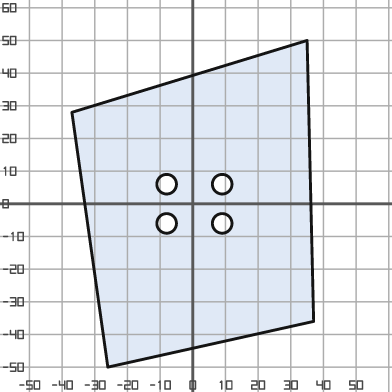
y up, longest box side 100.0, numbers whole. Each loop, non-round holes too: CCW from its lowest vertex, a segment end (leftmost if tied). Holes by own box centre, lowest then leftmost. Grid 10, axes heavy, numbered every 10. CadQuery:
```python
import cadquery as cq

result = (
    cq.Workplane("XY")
    .moveTo(-26.0, -50.0)
    .lineTo(37.0, -36.0)
    .lineTo(35.0, 50.0)
    .lineTo(-37.0, 28.0)
    .close()
    .moveTo(-8.0, -6.0)
    .circle(3.0)
    .moveTo(9.0, -6.0)
    .circle(3.0)
    .moveTo(-8.0, 6.0)
    .circle(3.0)
    .moveTo(9.0, 6.0)
    .circle(3.0)
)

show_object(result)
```